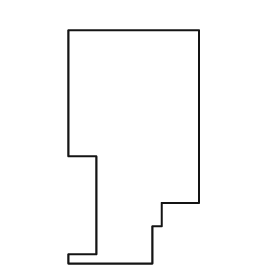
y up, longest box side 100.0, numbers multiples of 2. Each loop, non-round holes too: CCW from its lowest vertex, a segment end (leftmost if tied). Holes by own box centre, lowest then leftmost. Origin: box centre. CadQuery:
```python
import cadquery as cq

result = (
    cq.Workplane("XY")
    .moveTo(-28.0, -50.0)
    .lineTo(8.0, -50.0)
    .lineTo(8.0, -34.0)
    .lineTo(12.0, -34.0)
    .lineTo(12.0, -24.0)
    .lineTo(28.0, -24.0)
    .lineTo(28.0, 50.0)
    .lineTo(-28.0, 50.0)
    .lineTo(-28.0, -4.0)
    .lineTo(-16.0, -4.0)
    .lineTo(-16.0, -46.0)
    .lineTo(-28.0, -46.0)
    .close()
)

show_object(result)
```